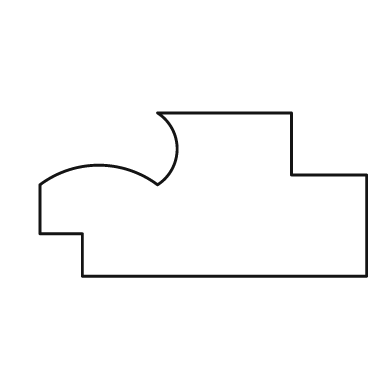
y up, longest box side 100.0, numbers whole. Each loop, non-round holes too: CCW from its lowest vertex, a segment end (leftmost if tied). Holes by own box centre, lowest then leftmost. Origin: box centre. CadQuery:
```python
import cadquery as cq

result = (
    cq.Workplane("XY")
    .moveTo(-37.0, -25.0)
    .lineTo(50.0, -25.0)
    .lineTo(50.0, 6.0)
    .lineTo(27.0, 6.0)
    .lineTo(27.0, 25.0)
    .lineTo(-14.0, 25.0)
    .threePointArc((-8.0, 14.0), (-14.0, 3.0))
    .threePointArc((-32.0, 9.0), (-50.0, 3.0))
    .lineTo(-50.0, -12.0)
    .lineTo(-37.0, -12.0)
    .close()
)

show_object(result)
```